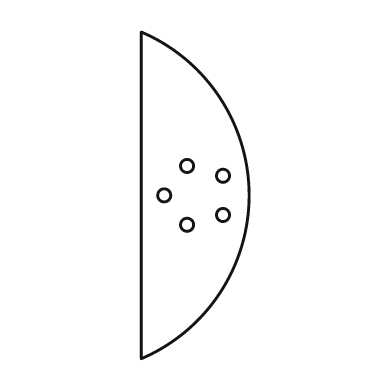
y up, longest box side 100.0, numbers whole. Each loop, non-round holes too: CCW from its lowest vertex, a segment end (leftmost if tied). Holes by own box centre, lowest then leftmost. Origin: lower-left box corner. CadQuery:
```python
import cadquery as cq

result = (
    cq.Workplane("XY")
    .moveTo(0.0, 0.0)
    .threePointArc((33.0, 50.0), (0.0, 100.0))
    .close()
    .moveTo(14.0, 41.0)
    .circle(2.0)
    .moveTo(25.0, 44.0)
    .circle(2.0)
    .moveTo(7.0, 50.0)
    .circle(2.0)
    .moveTo(25.0, 56.0)
    .circle(2.0)
    .moveTo(14.0, 59.0)
    .circle(2.0)
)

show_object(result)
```